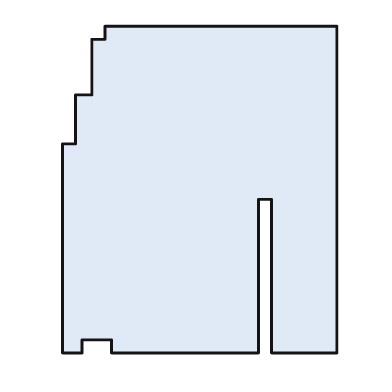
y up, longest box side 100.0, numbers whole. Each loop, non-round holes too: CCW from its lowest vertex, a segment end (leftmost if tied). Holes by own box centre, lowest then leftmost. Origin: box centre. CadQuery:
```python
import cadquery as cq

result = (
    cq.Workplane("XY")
    .moveTo(-42.0, -50.0)
    .lineTo(-36.0, -50.0)
    .lineTo(-36.0, -46.0)
    .lineTo(-27.0, -46.0)
    .lineTo(-27.0, -50.0)
    .lineTo(18.0, -50.0)
    .lineTo(18.0, -3.0)
    .lineTo(22.0, -3.0)
    .lineTo(22.0, -50.0)
    .lineTo(42.0, -50.0)
    .lineTo(42.0, 50.0)
    .lineTo(-29.0, 50.0)
    .lineTo(-29.0, 46.0)
    .lineTo(-33.0, 46.0)
    .lineTo(-33.0, 29.0)
    .lineTo(-38.0, 29.0)
    .lineTo(-38.0, 14.0)
    .lineTo(-42.0, 14.0)
    .close()
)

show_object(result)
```